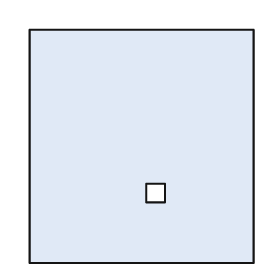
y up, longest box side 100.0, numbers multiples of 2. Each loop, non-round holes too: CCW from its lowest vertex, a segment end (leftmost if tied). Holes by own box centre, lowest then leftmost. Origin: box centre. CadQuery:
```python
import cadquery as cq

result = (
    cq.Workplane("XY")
    .moveTo(-48.0, -50.0)
    .lineTo(48.0, -50.0)
    .lineTo(48.0, 50.0)
    .lineTo(-48.0, 50.0)
    .close()
    .moveTo(2.0, -24.0)
    .lineTo(10.0, -24.0)
    .lineTo(10.0, -16.0)
    .lineTo(2.0, -16.0)
    .close()
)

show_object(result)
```